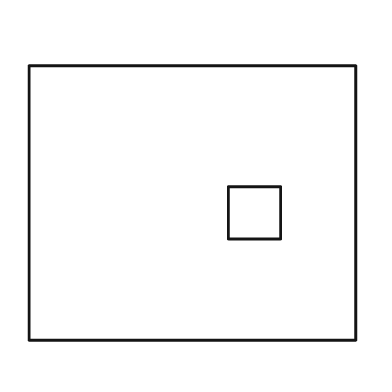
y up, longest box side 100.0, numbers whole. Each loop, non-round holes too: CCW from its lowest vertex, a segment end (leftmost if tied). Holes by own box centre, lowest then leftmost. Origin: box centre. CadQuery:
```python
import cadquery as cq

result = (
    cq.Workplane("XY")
    .moveTo(-50.0, -42.0)
    .lineTo(50.0, -42.0)
    .lineTo(50.0, 42.0)
    .lineTo(-50.0, 42.0)
    .close()
    .moveTo(11.0, -11.0)
    .lineTo(27.0, -11.0)
    .lineTo(27.0, 5.0)
    .lineTo(11.0, 5.0)
    .close()
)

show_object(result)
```